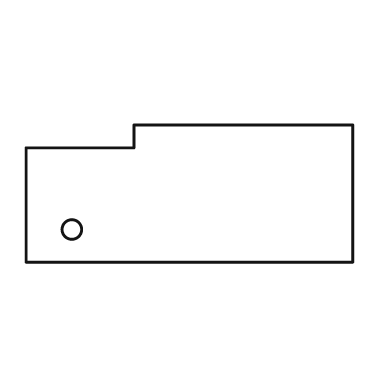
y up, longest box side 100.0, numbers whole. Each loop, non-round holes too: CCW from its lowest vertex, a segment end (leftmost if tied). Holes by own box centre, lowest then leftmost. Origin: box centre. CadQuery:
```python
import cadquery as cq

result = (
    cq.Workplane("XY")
    .moveTo(-50.0, -21.0)
    .lineTo(50.0, -21.0)
    .lineTo(50.0, 21.0)
    .lineTo(-17.0, 21.0)
    .lineTo(-17.0, 14.0)
    .lineTo(-50.0, 14.0)
    .close()
    .moveTo(-36.0, -11.0)
    .circle(3.0)
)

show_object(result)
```